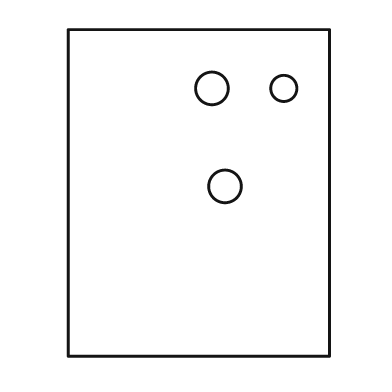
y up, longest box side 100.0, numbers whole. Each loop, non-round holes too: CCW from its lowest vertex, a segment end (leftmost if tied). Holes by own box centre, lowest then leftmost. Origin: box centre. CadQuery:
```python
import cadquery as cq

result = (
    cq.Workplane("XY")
    .moveTo(-40.0, -50.0)
    .lineTo(40.0, -50.0)
    .lineTo(40.0, 50.0)
    .lineTo(-40.0, 50.0)
    .close()
    .moveTo(8.0, 2.0)
    .circle(5.0)
    .moveTo(4.0, 32.0)
    .circle(5.0)
    .moveTo(26.0, 32.0)
    .circle(4.0)
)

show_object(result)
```